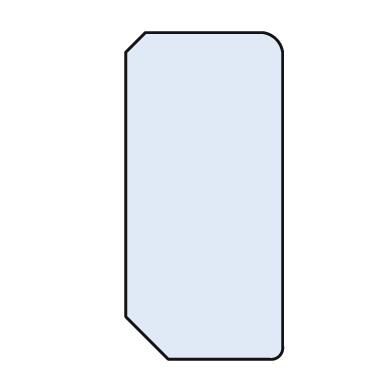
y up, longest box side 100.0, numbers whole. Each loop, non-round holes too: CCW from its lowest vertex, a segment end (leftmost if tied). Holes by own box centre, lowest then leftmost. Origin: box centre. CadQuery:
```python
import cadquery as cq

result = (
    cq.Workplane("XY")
    .moveTo(-11.0, -50.0)
    .lineTo(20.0, -50.0)
    .threePointArc((23.0, -49.0), (24.0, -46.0))
    .lineTo(24.0, 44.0)
    .threePointArc((22.0, 48.0), (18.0, 50.0))
    .lineTo(-18.0, 50.0)
    .lineTo(-24.0, 44.0)
    .lineTo(-24.0, -37.0)
    .close()
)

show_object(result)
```